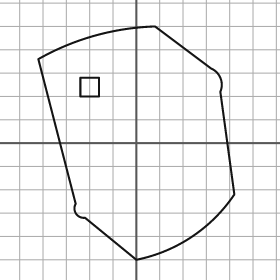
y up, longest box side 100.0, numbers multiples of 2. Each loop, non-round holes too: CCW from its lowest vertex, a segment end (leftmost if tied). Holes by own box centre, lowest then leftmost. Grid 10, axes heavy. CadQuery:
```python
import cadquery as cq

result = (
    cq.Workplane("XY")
    .moveTo(0.0, -50.0)
    .threePointArc((24.0, -40.0), (42.0, -22.0))
    .lineTo(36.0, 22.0)
    .threePointArc((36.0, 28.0), (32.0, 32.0))
    .lineTo(8.0, 50.0)
    .threePointArc((-18.0, 46.0), (-42.0, 36.0))
    .lineTo(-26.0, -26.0)
    .threePointArc((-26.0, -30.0), (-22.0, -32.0))
    .close()
    .moveTo(-24.0, 20.0)
    .lineTo(-16.0, 20.0)
    .lineTo(-16.0, 28.0)
    .lineTo(-24.0, 28.0)
    .close()
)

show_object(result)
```